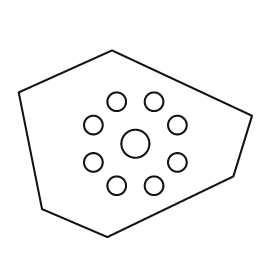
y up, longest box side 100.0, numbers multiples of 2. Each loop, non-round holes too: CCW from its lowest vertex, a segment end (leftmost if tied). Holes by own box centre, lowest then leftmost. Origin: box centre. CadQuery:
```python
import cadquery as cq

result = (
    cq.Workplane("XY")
    .moveTo(-12.0, -40.0)
    .lineTo(42.0, -14.0)
    .lineTo(50.0, 12.0)
    .lineTo(-10.0, 40.0)
    .lineTo(-50.0, 22.0)
    .lineTo(-40.0, -28.0)
    .close()
    .moveTo(-8.0, -18.0)
    .circle(4.0)
    .moveTo(8.0, -18.0)
    .circle(4.0)
    .moveTo(-18.0, -8.0)
    .circle(4.0)
    .moveTo(18.0, -8.0)
    .circle(4.0)
    .moveTo(0.0, 0.0)
    .circle(6.0)
    .moveTo(-18.0, 8.0)
    .circle(4.0)
    .moveTo(18.0, 8.0)
    .circle(4.0)
    .moveTo(-8.0, 18.0)
    .circle(4.0)
    .moveTo(8.0, 18.0)
    .circle(4.0)
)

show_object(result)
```